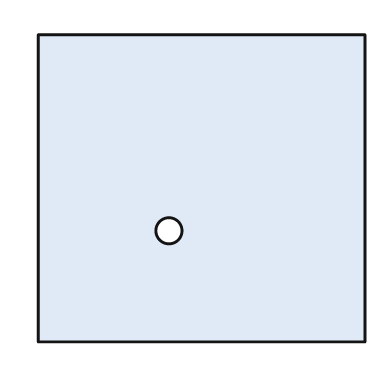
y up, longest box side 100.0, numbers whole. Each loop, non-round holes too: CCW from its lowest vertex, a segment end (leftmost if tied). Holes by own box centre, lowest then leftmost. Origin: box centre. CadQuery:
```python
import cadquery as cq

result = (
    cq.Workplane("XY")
    .moveTo(-50.0, -47.0)
    .lineTo(50.0, -47.0)
    .lineTo(50.0, 47.0)
    .lineTo(-50.0, 47.0)
    .close()
    .moveTo(-10.0, -13.0)
    .circle(4.0)
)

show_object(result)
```